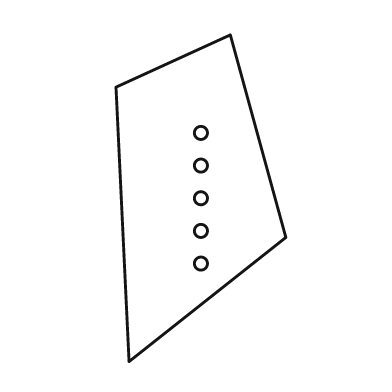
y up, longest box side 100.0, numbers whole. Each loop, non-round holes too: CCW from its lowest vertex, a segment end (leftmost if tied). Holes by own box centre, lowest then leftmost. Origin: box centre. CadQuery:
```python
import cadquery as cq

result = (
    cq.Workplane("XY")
    .moveTo(-22.0, -50.0)
    .lineTo(26.0, -12.0)
    .lineTo(9.0, 50.0)
    .lineTo(-26.0, 34.0)
    .close()
    .moveTo(0.0, -20.0)
    .circle(2.0)
    .moveTo(0.0, -10.0)
    .circle(2.0)
    .moveTo(0.0, 0.0)
    .circle(2.0)
    .moveTo(0.0, 10.0)
    .circle(2.0)
    .moveTo(0.0, 20.0)
    .circle(2.0)
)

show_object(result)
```